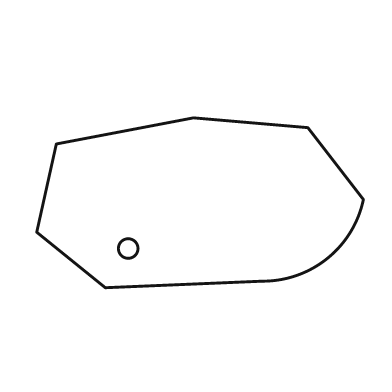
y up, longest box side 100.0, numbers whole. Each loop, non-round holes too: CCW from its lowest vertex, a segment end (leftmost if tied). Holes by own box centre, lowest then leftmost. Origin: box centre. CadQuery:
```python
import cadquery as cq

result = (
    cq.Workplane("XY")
    .moveTo(-29.0, -26.0)
    .lineTo(19.0, -24.0)
    .threePointArc((39.0, -17.0), (50.0, 1.0))
    .lineTo(33.0, 23.0)
    .lineTo(-2.0, 26.0)
    .lineTo(-44.0, 18.0)
    .lineTo(-50.0, -9.0)
    .close()
    .moveTo(-22.0, -14.0)
    .circle(3.0)
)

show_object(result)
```